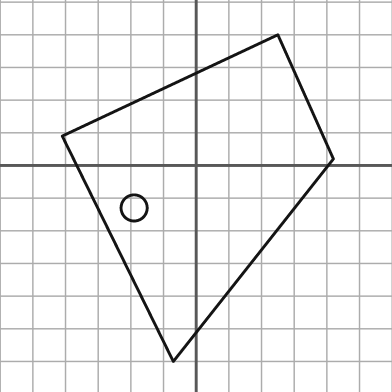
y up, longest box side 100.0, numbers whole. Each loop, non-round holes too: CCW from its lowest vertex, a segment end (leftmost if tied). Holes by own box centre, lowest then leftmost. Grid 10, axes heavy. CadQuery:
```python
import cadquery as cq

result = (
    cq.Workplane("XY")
    .moveTo(-7.0, -60.0)
    .lineTo(42.0, 2.0)
    .lineTo(25.0, 40.0)
    .lineTo(-41.0, 9.0)
    .close()
    .moveTo(-19.0, -13.0)
    .circle(4.0)
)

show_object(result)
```